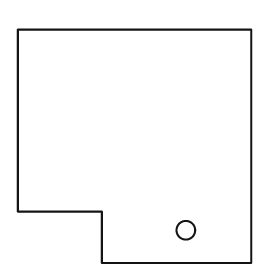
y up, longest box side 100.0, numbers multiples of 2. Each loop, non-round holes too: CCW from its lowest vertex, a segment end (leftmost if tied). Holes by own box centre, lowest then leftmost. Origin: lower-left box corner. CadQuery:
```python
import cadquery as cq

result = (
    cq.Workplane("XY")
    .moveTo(36.0, 0.0)
    .lineTo(100.0, 0.0)
    .lineTo(100.0, 100.0)
    .lineTo(0.0, 100.0)
    .lineTo(0.0, 22.0)
    .lineTo(36.0, 22.0)
    .close()
    .moveTo(72.0, 14.0)
    .circle(4.0)
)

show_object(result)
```